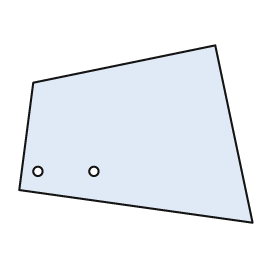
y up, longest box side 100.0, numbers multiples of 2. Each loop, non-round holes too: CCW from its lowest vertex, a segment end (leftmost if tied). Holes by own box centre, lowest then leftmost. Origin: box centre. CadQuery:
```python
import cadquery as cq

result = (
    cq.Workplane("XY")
    .moveTo(50.0, -38.0)
    .lineTo(34.0, 38.0)
    .lineTo(-44.0, 22.0)
    .lineTo(-50.0, -24.0)
    .close()
    .moveTo(-42.0, -16.0)
    .circle(2.0)
    .moveTo(-18.0, -16.0)
    .circle(2.0)
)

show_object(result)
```